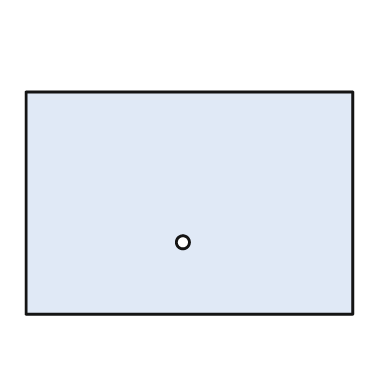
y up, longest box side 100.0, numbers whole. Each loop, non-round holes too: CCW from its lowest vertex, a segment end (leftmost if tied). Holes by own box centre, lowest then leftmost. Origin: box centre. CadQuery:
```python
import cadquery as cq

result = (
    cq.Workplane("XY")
    .moveTo(-50.0, -34.0)
    .lineTo(50.0, -34.0)
    .lineTo(50.0, 34.0)
    .lineTo(-50.0, 34.0)
    .close()
    .moveTo(-2.0, -12.0)
    .circle(2.0)
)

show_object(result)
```